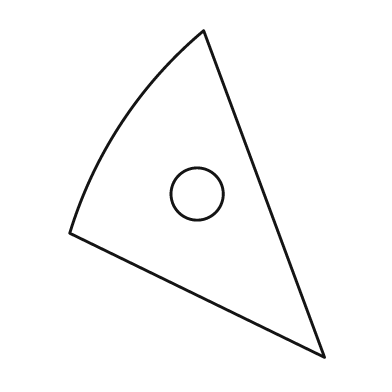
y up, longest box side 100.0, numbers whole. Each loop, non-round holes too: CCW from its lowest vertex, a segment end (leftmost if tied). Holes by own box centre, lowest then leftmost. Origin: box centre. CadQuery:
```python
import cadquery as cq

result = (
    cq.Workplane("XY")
    .moveTo(39.0, -50.0)
    .lineTo(2.0, 50.0)
    .threePointArc((-23.0, 22.0), (-39.0, -12.0))
    .close()
    .moveTo(0.0, 0.0)
    .circle(8.0)
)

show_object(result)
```